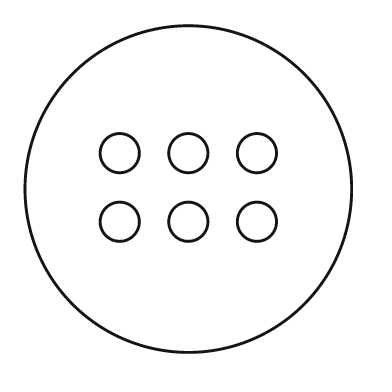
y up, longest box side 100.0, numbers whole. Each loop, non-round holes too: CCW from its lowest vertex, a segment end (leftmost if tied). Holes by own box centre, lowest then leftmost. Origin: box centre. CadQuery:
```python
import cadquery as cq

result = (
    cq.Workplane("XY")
    .moveTo(0.0, 0.0)
    .circle(50.0)
    .moveTo(-21.0, -10.0)
    .circle(6.0)
    .moveTo(0.0, -10.0)
    .circle(6.0)
    .moveTo(21.0, -10.0)
    .circle(6.0)
    .moveTo(-21.0, 11.0)
    .circle(6.0)
    .moveTo(0.0, 11.0)
    .circle(6.0)
    .moveTo(21.0, 11.0)
    .circle(6.0)
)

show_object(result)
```